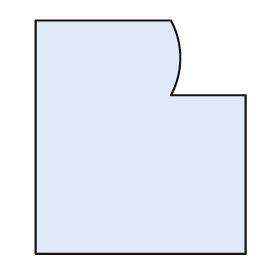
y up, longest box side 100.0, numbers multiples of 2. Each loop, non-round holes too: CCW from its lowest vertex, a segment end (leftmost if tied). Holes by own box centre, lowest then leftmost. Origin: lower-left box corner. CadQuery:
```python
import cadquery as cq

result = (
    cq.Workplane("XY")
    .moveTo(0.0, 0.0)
    .lineTo(90.0, 0.0)
    .lineTo(90.0, 68.0)
    .lineTo(58.0, 68.0)
    .threePointArc((62.0, 84.0), (58.0, 100.0))
    .lineTo(0.0, 100.0)
    .close()
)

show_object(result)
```